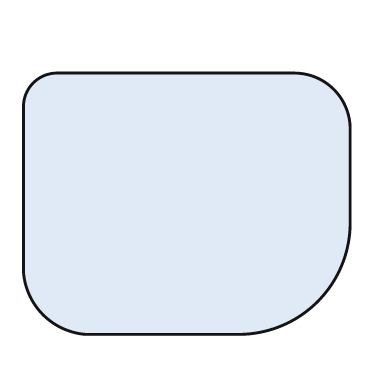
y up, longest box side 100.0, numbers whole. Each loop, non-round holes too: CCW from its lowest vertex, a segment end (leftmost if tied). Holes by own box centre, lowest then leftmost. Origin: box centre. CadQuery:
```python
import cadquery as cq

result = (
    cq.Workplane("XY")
    .moveTo(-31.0, -40.0)
    .lineTo(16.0, -40.0)
    .threePointArc((40.0, -30.0), (50.0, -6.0))
    .lineTo(50.0, 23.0)
    .threePointArc((45.0, 35.0), (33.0, 40.0))
    .lineTo(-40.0, 40.0)
    .threePointArc((-47.0, 37.0), (-50.0, 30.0))
    .lineTo(-50.0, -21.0)
    .threePointArc((-44.0, -34.0), (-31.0, -40.0))
    .close()
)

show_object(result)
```